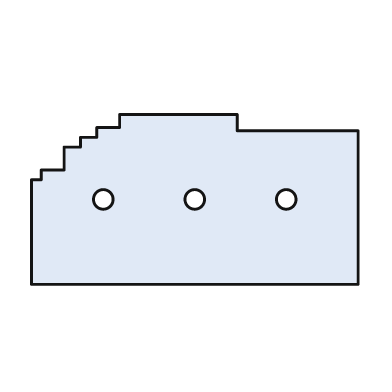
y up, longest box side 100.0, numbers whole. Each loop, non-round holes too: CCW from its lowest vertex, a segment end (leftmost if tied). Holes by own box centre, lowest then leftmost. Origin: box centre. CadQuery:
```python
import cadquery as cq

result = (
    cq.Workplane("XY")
    .moveTo(-50.0, -26.0)
    .lineTo(50.0, -26.0)
    .lineTo(50.0, 21.0)
    .lineTo(13.0, 21.0)
    .lineTo(13.0, 26.0)
    .lineTo(-23.0, 26.0)
    .lineTo(-23.0, 22.0)
    .lineTo(-30.0, 22.0)
    .lineTo(-30.0, 19.0)
    .lineTo(-35.0, 19.0)
    .lineTo(-35.0, 16.0)
    .lineTo(-40.0, 16.0)
    .lineTo(-40.0, 9.0)
    .lineTo(-47.0, 9.0)
    .lineTo(-47.0, 6.0)
    .lineTo(-50.0, 6.0)
    .close()
    .moveTo(-28.0, 0.0)
    .circle(3.0)
    .moveTo(0.0, 0.0)
    .circle(3.0)
    .moveTo(28.0, 0.0)
    .circle(3.0)
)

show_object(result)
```